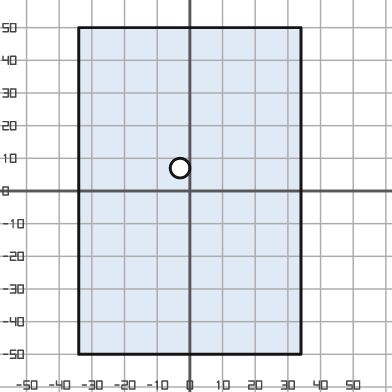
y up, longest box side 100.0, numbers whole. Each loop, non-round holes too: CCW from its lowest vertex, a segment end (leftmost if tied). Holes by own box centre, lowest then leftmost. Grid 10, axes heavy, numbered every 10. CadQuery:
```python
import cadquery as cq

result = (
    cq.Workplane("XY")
    .moveTo(-34.0, -50.0)
    .lineTo(34.0, -50.0)
    .lineTo(34.0, 50.0)
    .lineTo(-34.0, 50.0)
    .close()
    .moveTo(-3.0, 7.0)
    .circle(3.0)
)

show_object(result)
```